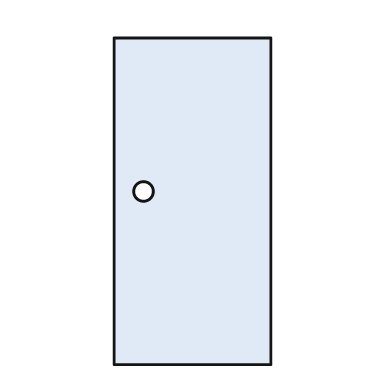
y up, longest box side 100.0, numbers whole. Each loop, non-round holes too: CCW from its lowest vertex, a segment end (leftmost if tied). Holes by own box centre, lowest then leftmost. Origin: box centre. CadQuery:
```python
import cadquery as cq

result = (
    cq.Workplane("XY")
    .moveTo(-24.0, -50.0)
    .lineTo(24.0, -50.0)
    .lineTo(24.0, 50.0)
    .lineTo(-24.0, 50.0)
    .close()
    .moveTo(-15.0, 3.0)
    .circle(3.0)
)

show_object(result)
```